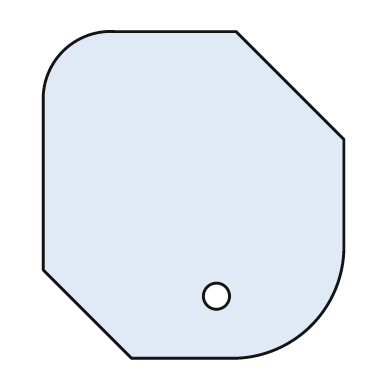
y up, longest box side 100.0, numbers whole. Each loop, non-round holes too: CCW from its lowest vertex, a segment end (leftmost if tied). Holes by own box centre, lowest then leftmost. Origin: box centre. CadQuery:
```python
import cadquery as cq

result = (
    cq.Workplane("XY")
    .moveTo(-19.0, -50.0)
    .lineTo(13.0, -50.0)
    .threePointArc((36.0, -40.0), (46.0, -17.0))
    .lineTo(46.0, 17.0)
    .lineTo(13.0, 50.0)
    .lineTo(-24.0, 50.0)
    .threePointArc((-40.0, 44.0), (-46.0, 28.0))
    .lineTo(-46.0, -23.0)
    .close()
    .moveTo(7.0, -31.0)
    .circle(4.0)
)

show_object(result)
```